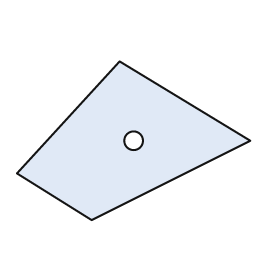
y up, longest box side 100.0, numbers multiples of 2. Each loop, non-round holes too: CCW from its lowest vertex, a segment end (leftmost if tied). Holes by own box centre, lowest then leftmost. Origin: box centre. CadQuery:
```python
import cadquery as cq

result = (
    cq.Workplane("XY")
    .moveTo(-18.0, -34.0)
    .lineTo(50.0, 0.0)
    .lineTo(-6.0, 34.0)
    .lineTo(-50.0, -14.0)
    .close()
    .moveTo(0.0, 0.0)
    .circle(4.0)
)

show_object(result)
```